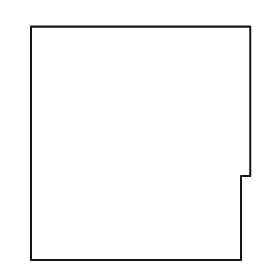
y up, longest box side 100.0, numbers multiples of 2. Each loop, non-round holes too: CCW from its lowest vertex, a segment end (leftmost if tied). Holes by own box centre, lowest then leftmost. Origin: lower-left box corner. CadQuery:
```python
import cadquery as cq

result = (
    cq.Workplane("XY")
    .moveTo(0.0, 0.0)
    .lineTo(90.0, 0.0)
    .lineTo(90.0, 36.0)
    .lineTo(94.0, 36.0)
    .lineTo(94.0, 100.0)
    .lineTo(0.0, 100.0)
    .close()
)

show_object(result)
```